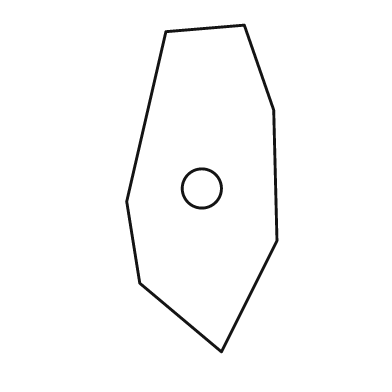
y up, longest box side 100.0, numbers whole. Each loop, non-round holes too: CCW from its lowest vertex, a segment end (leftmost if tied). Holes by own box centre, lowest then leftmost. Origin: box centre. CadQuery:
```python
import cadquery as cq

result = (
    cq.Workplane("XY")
    .moveTo(6.0, -50.0)
    .lineTo(23.0, -16.0)
    .lineTo(22.0, 24.0)
    .lineTo(13.0, 50.0)
    .lineTo(-11.0, 48.0)
    .lineTo(-23.0, -4.0)
    .lineTo(-19.0, -29.0)
    .close()
    .moveTo(0.0, 0.0)
    .circle(6.0)
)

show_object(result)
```